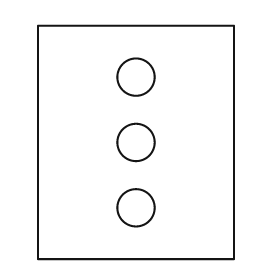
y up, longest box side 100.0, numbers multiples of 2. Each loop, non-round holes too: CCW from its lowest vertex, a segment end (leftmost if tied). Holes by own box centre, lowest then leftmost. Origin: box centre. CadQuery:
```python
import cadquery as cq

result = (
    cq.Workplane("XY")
    .moveTo(-42.0, -50.0)
    .lineTo(42.0, -50.0)
    .lineTo(42.0, 50.0)
    .lineTo(-42.0, 50.0)
    .close()
    .moveTo(0.0, -28.0)
    .circle(8.0)
    .moveTo(0.0, 0.0)
    .circle(8.0)
    .moveTo(0.0, 28.0)
    .circle(8.0)
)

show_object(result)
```